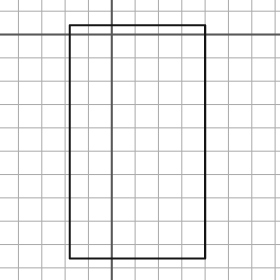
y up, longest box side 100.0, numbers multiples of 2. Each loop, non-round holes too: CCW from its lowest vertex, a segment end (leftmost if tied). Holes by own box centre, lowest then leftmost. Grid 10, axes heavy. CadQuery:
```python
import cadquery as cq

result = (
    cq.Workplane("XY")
    .moveTo(-18.0, -96.0)
    .lineTo(40.0, -96.0)
    .lineTo(40.0, 4.0)
    .lineTo(-18.0, 4.0)
    .close()
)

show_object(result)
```